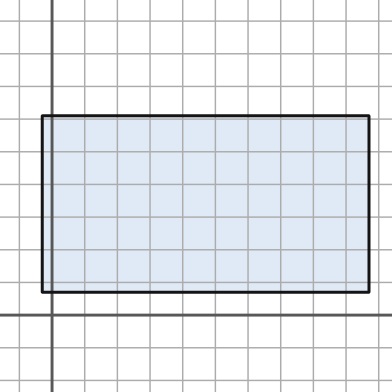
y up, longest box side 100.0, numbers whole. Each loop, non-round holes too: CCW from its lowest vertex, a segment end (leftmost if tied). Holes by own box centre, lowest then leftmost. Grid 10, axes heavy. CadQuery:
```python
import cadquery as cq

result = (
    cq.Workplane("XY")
    .moveTo(-3.0, 7.0)
    .lineTo(97.0, 7.0)
    .lineTo(97.0, 61.0)
    .lineTo(-3.0, 61.0)
    .close()
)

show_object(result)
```